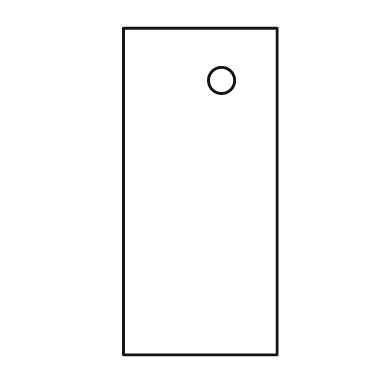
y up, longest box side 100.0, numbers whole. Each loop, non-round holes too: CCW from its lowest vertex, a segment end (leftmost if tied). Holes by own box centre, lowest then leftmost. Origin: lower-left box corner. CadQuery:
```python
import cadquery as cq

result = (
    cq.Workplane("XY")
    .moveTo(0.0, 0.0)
    .lineTo(47.0, 0.0)
    .lineTo(47.0, 100.0)
    .lineTo(0.0, 100.0)
    .close()
    .moveTo(30.0, 84.0)
    .circle(4.0)
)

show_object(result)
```